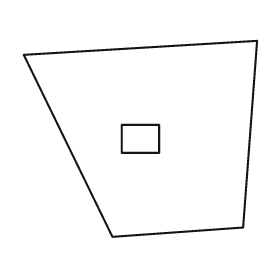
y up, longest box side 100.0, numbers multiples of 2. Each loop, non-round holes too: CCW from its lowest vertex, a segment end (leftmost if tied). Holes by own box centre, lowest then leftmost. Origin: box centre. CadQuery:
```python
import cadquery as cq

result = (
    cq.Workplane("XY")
    .moveTo(-12.0, -42.0)
    .lineTo(44.0, -38.0)
    .lineTo(50.0, 42.0)
    .lineTo(-50.0, 36.0)
    .close()
    .moveTo(-8.0, -6.0)
    .lineTo(8.0, -6.0)
    .lineTo(8.0, 6.0)
    .lineTo(-8.0, 6.0)
    .close()
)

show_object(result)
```